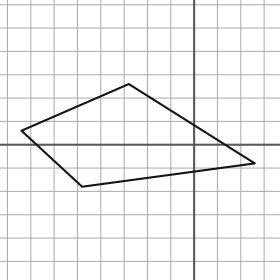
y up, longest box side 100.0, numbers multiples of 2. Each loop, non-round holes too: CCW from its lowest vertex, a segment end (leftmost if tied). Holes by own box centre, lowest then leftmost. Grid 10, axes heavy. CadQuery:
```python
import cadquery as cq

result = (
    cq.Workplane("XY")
    .moveTo(-48.0, -18.0)
    .lineTo(26.0, -8.0)
    .lineTo(-28.0, 26.0)
    .lineTo(-74.0, 6.0)
    .close()
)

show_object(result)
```